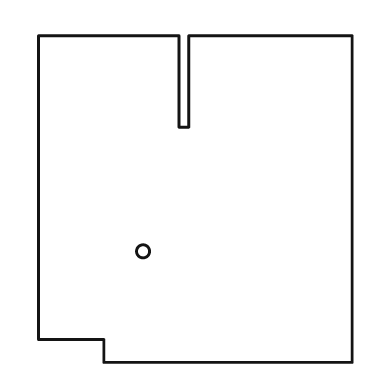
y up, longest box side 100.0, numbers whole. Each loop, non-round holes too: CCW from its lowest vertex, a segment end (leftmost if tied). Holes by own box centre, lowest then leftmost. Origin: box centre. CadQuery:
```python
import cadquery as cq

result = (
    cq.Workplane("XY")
    .moveTo(-28.0, -50.0)
    .lineTo(48.0, -50.0)
    .lineTo(48.0, 50.0)
    .lineTo(-2.0, 50.0)
    .lineTo(-2.0, 22.0)
    .lineTo(-5.0, 22.0)
    .lineTo(-5.0, 50.0)
    .lineTo(-48.0, 50.0)
    .lineTo(-48.0, -43.0)
    .lineTo(-28.0, -43.0)
    .close()
    .moveTo(-16.0, -16.0)
    .circle(2.0)
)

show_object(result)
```